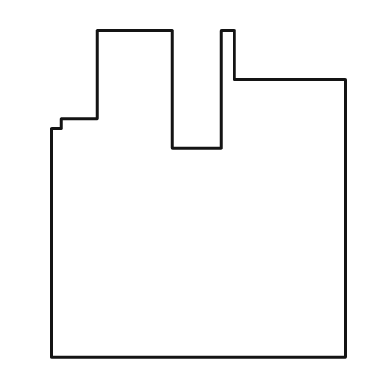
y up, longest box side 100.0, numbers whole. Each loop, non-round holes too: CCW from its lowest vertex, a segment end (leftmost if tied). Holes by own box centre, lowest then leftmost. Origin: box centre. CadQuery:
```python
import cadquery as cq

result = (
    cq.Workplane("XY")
    .moveTo(-45.0, -50.0)
    .lineTo(45.0, -50.0)
    .lineTo(45.0, 35.0)
    .lineTo(11.0, 35.0)
    .lineTo(11.0, 50.0)
    .lineTo(7.0, 50.0)
    .lineTo(7.0, 14.0)
    .lineTo(-8.0, 14.0)
    .lineTo(-8.0, 50.0)
    .lineTo(-31.0, 50.0)
    .lineTo(-31.0, 23.0)
    .lineTo(-42.0, 23.0)
    .lineTo(-42.0, 20.0)
    .lineTo(-45.0, 20.0)
    .close()
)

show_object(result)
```